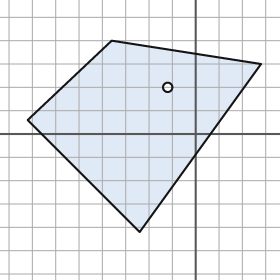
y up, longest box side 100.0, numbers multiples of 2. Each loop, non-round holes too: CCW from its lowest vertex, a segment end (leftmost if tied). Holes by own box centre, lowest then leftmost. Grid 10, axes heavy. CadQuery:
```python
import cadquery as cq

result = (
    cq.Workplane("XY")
    .moveTo(-24.0, -42.0)
    .lineTo(28.0, 30.0)
    .lineTo(-36.0, 40.0)
    .lineTo(-72.0, 6.0)
    .close()
    .moveTo(-12.0, 20.0)
    .circle(2.0)
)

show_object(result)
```